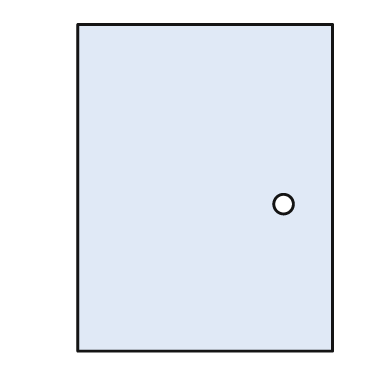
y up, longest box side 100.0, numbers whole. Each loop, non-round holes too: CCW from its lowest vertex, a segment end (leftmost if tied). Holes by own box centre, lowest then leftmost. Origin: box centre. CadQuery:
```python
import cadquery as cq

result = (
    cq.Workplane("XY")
    .moveTo(-39.0, -50.0)
    .lineTo(39.0, -50.0)
    .lineTo(39.0, 50.0)
    .lineTo(-39.0, 50.0)
    .close()
    .moveTo(24.0, -5.0)
    .circle(3.0)
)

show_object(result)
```